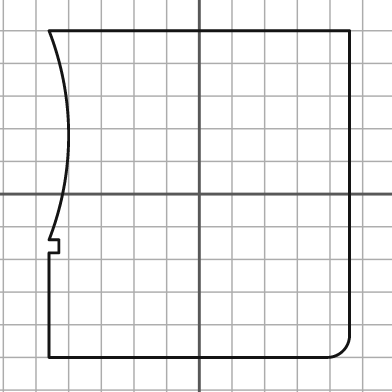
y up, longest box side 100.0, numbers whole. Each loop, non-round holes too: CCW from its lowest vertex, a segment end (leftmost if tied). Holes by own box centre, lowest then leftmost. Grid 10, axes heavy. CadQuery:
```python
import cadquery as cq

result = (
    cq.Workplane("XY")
    .moveTo(-46.0, -50.0)
    .lineTo(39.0, -50.0)
    .threePointArc((44.0, -48.0), (46.0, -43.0))
    .lineTo(46.0, 50.0)
    .lineTo(-46.0, 50.0)
    .threePointArc((-40.0, 18.0), (-46.0, -14.0))
    .lineTo(-43.0, -14.0)
    .lineTo(-43.0, -18.0)
    .lineTo(-46.0, -18.0)
    .close()
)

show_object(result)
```